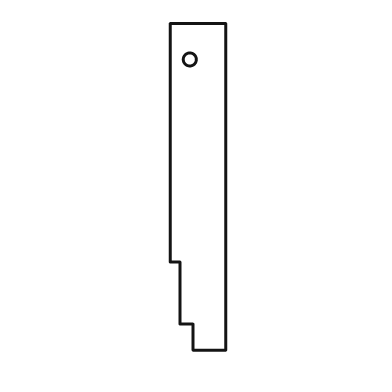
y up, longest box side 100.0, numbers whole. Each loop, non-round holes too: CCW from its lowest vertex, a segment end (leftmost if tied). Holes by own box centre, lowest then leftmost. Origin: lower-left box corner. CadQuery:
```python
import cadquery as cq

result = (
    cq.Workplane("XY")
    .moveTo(7.0, 0.0)
    .lineTo(17.0, 0.0)
    .lineTo(17.0, 100.0)
    .lineTo(0.0, 100.0)
    .lineTo(0.0, 27.0)
    .lineTo(3.0, 27.0)
    .lineTo(3.0, 8.0)
    .lineTo(7.0, 8.0)
    .close()
    .moveTo(6.0, 89.0)
    .circle(2.0)
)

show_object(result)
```